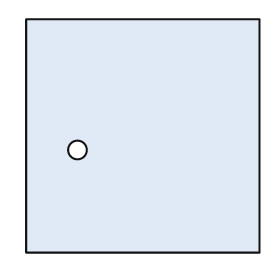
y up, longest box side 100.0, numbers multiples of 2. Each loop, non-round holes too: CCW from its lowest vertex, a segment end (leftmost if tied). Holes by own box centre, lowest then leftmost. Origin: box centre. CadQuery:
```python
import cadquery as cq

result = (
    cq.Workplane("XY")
    .moveTo(-50.0, -50.0)
    .lineTo(50.0, -50.0)
    .lineTo(50.0, 50.0)
    .lineTo(-50.0, 50.0)
    .close()
    .moveTo(-28.0, -6.0)
    .circle(4.0)
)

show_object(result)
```